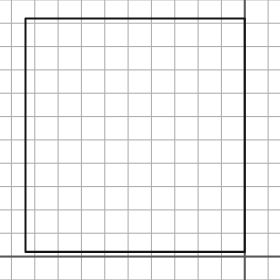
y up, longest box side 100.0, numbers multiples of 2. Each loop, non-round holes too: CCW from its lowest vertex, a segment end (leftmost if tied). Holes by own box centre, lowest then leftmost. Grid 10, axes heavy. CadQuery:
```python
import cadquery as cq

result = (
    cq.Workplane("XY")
    .moveTo(-94.0, 2.0)
    .lineTo(0.0, 2.0)
    .lineTo(0.0, 102.0)
    .lineTo(-94.0, 102.0)
    .close()
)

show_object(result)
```